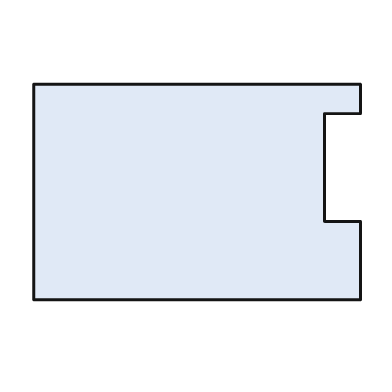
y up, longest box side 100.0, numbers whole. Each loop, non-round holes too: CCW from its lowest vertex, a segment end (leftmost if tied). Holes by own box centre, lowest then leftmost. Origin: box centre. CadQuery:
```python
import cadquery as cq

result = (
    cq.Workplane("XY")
    .moveTo(-50.0, -33.0)
    .lineTo(50.0, -33.0)
    .lineTo(50.0, -9.0)
    .lineTo(39.0, -9.0)
    .lineTo(39.0, 24.0)
    .lineTo(50.0, 24.0)
    .lineTo(50.0, 33.0)
    .lineTo(-50.0, 33.0)
    .close()
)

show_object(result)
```